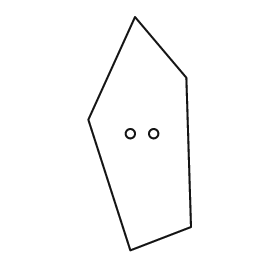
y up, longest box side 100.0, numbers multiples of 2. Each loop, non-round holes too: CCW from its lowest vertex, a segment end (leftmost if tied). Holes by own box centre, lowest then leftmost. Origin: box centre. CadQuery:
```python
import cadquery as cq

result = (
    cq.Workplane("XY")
    .moveTo(-4.0, -50.0)
    .lineTo(22.0, -40.0)
    .lineTo(20.0, 24.0)
    .lineTo(-2.0, 50.0)
    .lineTo(-22.0, 6.0)
    .close()
    .moveTo(-4.0, 0.0)
    .circle(2.0)
    .moveTo(6.0, 0.0)
    .circle(2.0)
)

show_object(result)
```